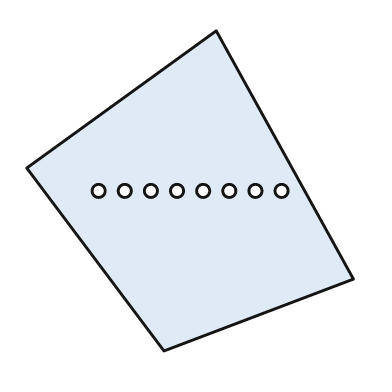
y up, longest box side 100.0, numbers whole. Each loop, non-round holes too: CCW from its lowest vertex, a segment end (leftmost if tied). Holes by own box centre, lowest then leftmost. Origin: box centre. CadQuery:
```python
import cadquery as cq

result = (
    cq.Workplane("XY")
    .moveTo(-8.0, -49.0)
    .lineTo(50.0, -27.0)
    .lineTo(8.0, 49.0)
    .lineTo(-50.0, 7.0)
    .close()
    .moveTo(-28.0, 0.0)
    .circle(2.0)
    .moveTo(-20.0, 0.0)
    .circle(2.0)
    .moveTo(-12.0, 0.0)
    .circle(2.0)
    .moveTo(-4.0, 0.0)
    .circle(2.0)
    .moveTo(4.0, 0.0)
    .circle(2.0)
    .moveTo(12.0, 0.0)
    .circle(2.0)
    .moveTo(20.0, 0.0)
    .circle(2.0)
    .moveTo(28.0, 0.0)
    .circle(2.0)
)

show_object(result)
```